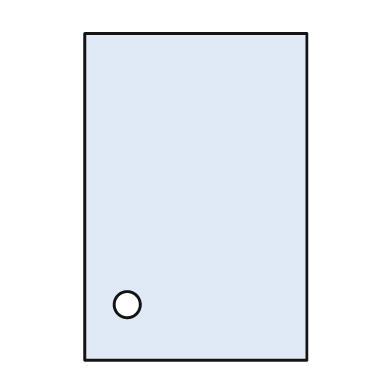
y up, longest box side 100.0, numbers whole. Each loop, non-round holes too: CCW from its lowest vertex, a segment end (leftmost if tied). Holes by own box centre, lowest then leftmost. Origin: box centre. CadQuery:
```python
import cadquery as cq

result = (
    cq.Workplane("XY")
    .moveTo(-34.0, -50.0)
    .lineTo(34.0, -50.0)
    .lineTo(34.0, 50.0)
    .lineTo(-34.0, 50.0)
    .close()
    .moveTo(-21.0, -33.0)
    .circle(4.0)
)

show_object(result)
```